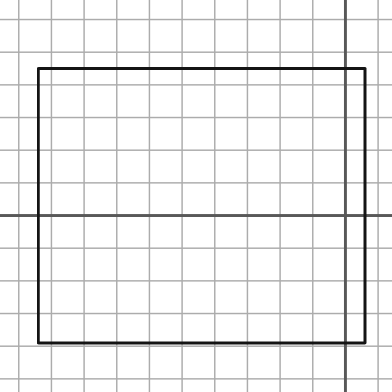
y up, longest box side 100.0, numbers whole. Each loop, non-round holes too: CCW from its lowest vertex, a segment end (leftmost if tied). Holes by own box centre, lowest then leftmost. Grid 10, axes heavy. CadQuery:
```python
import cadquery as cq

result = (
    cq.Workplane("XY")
    .moveTo(-94.0, -39.0)
    .lineTo(6.0, -39.0)
    .lineTo(6.0, 45.0)
    .lineTo(-94.0, 45.0)
    .close()
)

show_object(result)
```